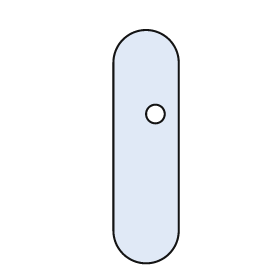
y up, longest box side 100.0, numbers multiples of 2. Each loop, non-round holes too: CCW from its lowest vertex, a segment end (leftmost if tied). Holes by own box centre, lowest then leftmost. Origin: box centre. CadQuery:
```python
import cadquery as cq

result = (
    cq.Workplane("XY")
    .moveTo(-14.0, -36.0)
    .threePointArc((0.0, -50.0), (14.0, -36.0))
    .lineTo(14.0, 36.0)
    .threePointArc((0.0, 50.0), (-14.0, 36.0))
    .close()
    .moveTo(4.0, 14.0)
    .circle(4.0)
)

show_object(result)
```